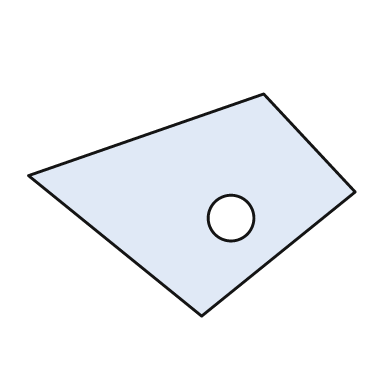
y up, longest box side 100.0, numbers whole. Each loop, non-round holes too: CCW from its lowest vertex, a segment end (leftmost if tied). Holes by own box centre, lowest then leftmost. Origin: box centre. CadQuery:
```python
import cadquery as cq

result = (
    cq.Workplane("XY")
    .moveTo(3.0, -34.0)
    .lineTo(50.0, 4.0)
    .lineTo(22.0, 34.0)
    .lineTo(-50.0, 9.0)
    .close()
    .moveTo(12.0, -4.0)
    .circle(7.0)
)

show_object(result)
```